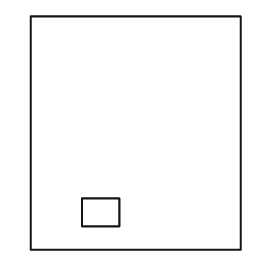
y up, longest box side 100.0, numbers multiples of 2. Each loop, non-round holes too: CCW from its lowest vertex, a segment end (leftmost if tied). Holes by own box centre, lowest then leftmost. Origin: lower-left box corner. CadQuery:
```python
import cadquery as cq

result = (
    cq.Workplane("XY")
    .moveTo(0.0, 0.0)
    .lineTo(90.0, 0.0)
    .lineTo(90.0, 100.0)
    .lineTo(0.0, 100.0)
    .close()
    .moveTo(22.0, 10.0)
    .lineTo(38.0, 10.0)
    .lineTo(38.0, 22.0)
    .lineTo(22.0, 22.0)
    .close()
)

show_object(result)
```